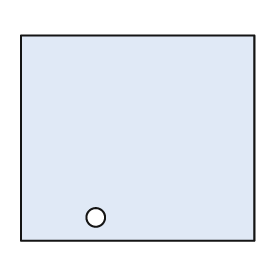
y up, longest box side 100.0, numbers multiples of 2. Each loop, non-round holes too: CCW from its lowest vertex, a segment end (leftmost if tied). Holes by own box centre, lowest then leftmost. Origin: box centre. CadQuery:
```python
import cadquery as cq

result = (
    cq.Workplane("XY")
    .moveTo(-50.0, -44.0)
    .lineTo(50.0, -44.0)
    .lineTo(50.0, 44.0)
    .lineTo(-50.0, 44.0)
    .close()
    .moveTo(-18.0, -34.0)
    .circle(4.0)
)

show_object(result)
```